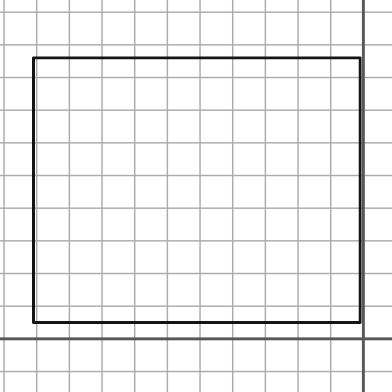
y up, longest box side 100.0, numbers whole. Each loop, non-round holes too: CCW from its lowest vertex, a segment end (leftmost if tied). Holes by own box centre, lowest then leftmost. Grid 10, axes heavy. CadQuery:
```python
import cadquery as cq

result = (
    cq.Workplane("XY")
    .moveTo(-101.0, 5.0)
    .lineTo(-1.0, 5.0)
    .lineTo(-1.0, 86.0)
    .lineTo(-101.0, 86.0)
    .close()
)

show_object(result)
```